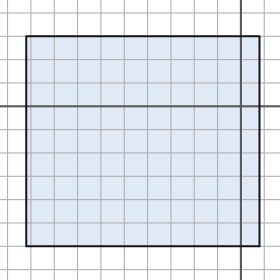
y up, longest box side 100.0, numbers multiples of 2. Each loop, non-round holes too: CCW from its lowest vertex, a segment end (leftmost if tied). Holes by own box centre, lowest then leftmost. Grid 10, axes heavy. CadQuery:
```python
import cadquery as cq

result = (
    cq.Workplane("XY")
    .moveTo(-92.0, -60.0)
    .lineTo(8.0, -60.0)
    .lineTo(8.0, 30.0)
    .lineTo(-92.0, 30.0)
    .close()
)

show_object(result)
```